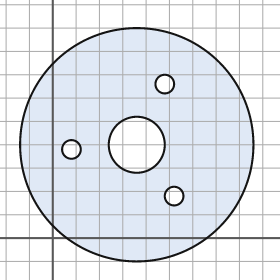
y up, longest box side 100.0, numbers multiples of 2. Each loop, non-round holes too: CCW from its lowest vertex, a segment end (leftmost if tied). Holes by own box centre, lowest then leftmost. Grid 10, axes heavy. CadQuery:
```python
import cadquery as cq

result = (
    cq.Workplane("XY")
    .moveTo(36.0, 40.0)
    .circle(50.0)
    .moveTo(52.0, 18.0)
    .circle(4.0)
    .moveTo(8.0, 38.0)
    .circle(4.0)
    .moveTo(36.0, 40.0)
    .circle(12.0)
    .moveTo(48.0, 66.0)
    .circle(4.0)
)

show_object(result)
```